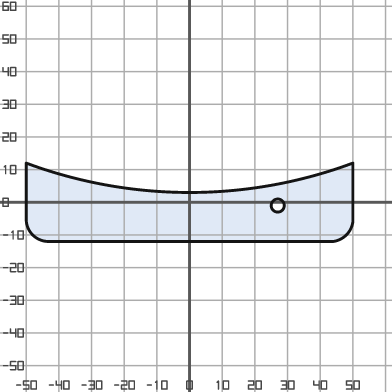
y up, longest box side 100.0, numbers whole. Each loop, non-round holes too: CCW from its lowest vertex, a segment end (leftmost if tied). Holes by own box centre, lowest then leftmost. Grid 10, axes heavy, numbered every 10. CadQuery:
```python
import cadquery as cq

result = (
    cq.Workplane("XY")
    .moveTo(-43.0, -12.0)
    .lineTo(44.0, -12.0)
    .threePointArc((48.0, -10.0), (50.0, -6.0))
    .lineTo(50.0, 12.0)
    .threePointArc((0.0, 3.0), (-50.0, 12.0))
    .lineTo(-50.0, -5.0)
    .threePointArc((-48.0, -10.0), (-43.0, -12.0))
    .close()
    .moveTo(27.0, -1.0)
    .circle(2.0)
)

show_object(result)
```